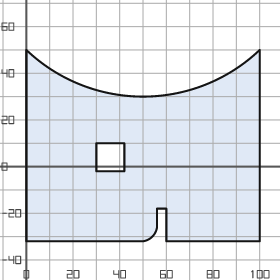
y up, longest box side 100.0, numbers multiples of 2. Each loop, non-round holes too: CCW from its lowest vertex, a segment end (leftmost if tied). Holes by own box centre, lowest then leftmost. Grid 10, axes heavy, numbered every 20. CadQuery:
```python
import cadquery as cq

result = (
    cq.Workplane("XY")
    .moveTo(0.0, -32.0)
    .lineTo(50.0, -32.0)
    .threePointArc((54.0, -30.0), (56.0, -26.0))
    .lineTo(56.0, -18.0)
    .lineTo(60.0, -18.0)
    .lineTo(60.0, -32.0)
    .lineTo(100.0, -32.0)
    .lineTo(100.0, 50.0)
    .threePointArc((50.0, 30.0), (0.0, 50.0))
    .close()
    .moveTo(30.0, -2.0)
    .lineTo(42.0, -2.0)
    .lineTo(42.0, 10.0)
    .lineTo(30.0, 10.0)
    .close()
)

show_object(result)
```